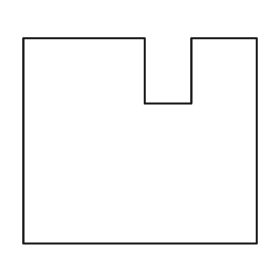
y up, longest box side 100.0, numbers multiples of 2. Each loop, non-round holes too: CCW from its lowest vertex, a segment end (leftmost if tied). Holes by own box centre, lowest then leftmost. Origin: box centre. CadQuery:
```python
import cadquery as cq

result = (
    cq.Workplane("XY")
    .moveTo(-50.0, -44.0)
    .lineTo(50.0, -44.0)
    .lineTo(50.0, 44.0)
    .lineTo(22.0, 44.0)
    .lineTo(22.0, 16.0)
    .lineTo(2.0, 16.0)
    .lineTo(2.0, 44.0)
    .lineTo(-50.0, 44.0)
    .close()
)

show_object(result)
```